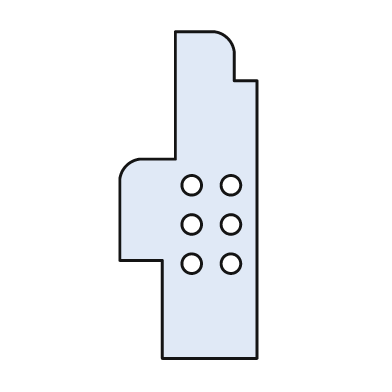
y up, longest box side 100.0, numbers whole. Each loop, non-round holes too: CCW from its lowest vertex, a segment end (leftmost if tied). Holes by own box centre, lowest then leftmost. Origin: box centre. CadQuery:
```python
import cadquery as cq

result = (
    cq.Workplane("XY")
    .moveTo(-8.0, -50.0)
    .lineTo(21.0, -50.0)
    .lineTo(21.0, 35.0)
    .lineTo(14.0, 35.0)
    .lineTo(14.0, 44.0)
    .threePointArc((12.0, 48.0), (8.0, 50.0))
    .lineTo(-4.0, 50.0)
    .lineTo(-4.0, 11.0)
    .lineTo(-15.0, 11.0)
    .threePointArc((-19.0, 9.0), (-21.0, 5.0))
    .lineTo(-21.0, -20.0)
    .lineTo(-8.0, -20.0)
    .close()
    .moveTo(1.0, -21.0)
    .circle(3.0)
    .moveTo(13.0, -21.0)
    .circle(3.0)
    .moveTo(1.0, -9.0)
    .circle(3.0)
    .moveTo(13.0, -9.0)
    .circle(3.0)
    .moveTo(1.0, 3.0)
    .circle(3.0)
    .moveTo(13.0, 3.0)
    .circle(3.0)
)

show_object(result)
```